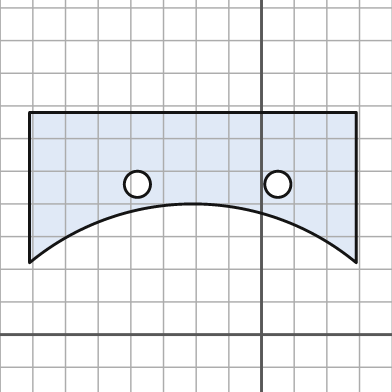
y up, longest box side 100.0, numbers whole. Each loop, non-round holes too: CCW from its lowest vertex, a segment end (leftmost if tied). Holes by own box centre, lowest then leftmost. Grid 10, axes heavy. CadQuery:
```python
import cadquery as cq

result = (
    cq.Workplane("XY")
    .moveTo(-71.0, 22.0)
    .threePointArc((-21.0, 40.0), (29.0, 22.0))
    .lineTo(29.0, 68.0)
    .lineTo(-71.0, 68.0)
    .close()
    .moveTo(-38.0, 46.0)
    .circle(4.0)
    .moveTo(5.0, 46.0)
    .circle(4.0)
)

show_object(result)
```